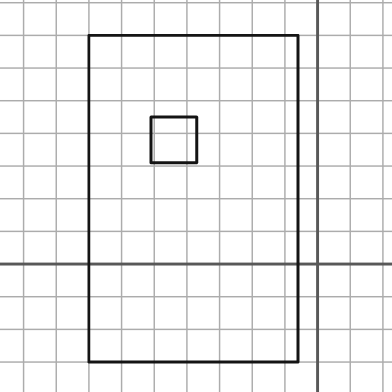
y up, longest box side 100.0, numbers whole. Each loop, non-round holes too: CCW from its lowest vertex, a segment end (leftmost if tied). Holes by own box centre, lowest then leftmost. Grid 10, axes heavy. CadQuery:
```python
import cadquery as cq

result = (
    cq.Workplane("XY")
    .moveTo(-70.0, -30.0)
    .lineTo(-6.0, -30.0)
    .lineTo(-6.0, 70.0)
    .lineTo(-70.0, 70.0)
    .close()
    .moveTo(-51.0, 31.0)
    .lineTo(-37.0, 31.0)
    .lineTo(-37.0, 45.0)
    .lineTo(-51.0, 45.0)
    .close()
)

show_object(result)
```